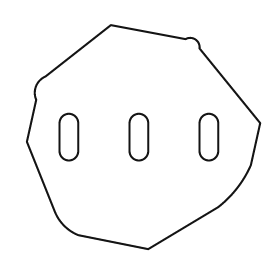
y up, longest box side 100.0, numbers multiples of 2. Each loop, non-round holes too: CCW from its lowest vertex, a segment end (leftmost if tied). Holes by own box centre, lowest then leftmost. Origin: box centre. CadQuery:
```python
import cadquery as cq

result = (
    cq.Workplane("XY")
    .moveTo(2.0, -48.0)
    .lineTo(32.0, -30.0)
    .threePointArc((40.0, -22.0), (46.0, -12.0))
    .lineTo(50.0, 6.0)
    .lineTo(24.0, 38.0)
    .threePointArc((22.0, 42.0), (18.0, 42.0))
    .lineTo(-14.0, 48.0)
    .lineTo(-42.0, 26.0)
    .threePointArc((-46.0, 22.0), (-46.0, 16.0))
    .lineTo(-50.0, -2.0)
    .lineTo(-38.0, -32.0)
    .threePointArc((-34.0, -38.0), (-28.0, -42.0))
    .close()
    .moveTo(-36.0, -6.0)
    .threePointArc((-32.0, -10.0), (-28.0, -6.0))
    .lineTo(-28.0, 6.0)
    .threePointArc((-32.0, 10.0), (-36.0, 6.0))
    .close()
    .moveTo(-6.0, -6.0)
    .threePointArc((-2.0, -10.0), (2.0, -6.0))
    .lineTo(2.0, 6.0)
    .threePointArc((-2.0, 10.0), (-6.0, 6.0))
    .close()
    .moveTo(24.0, -6.0)
    .threePointArc((28.0, -10.0), (32.0, -6.0))
    .lineTo(32.0, 6.0)
    .threePointArc((28.0, 10.0), (24.0, 6.0))
    .close()
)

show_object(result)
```